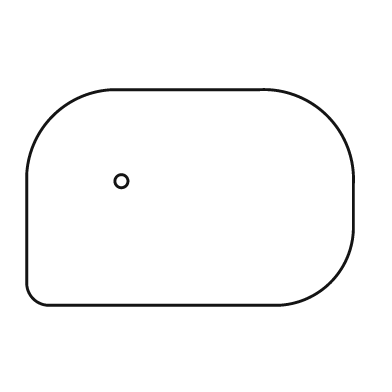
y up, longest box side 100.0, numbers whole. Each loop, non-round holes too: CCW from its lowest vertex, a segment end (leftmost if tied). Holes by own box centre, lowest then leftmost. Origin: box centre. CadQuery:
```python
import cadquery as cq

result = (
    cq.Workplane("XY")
    .moveTo(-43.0, -33.0)
    .lineTo(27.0, -33.0)
    .threePointArc((43.0, -26.0), (50.0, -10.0))
    .lineTo(50.0, 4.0)
    .threePointArc((42.0, 25.0), (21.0, 33.0))
    .lineTo(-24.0, 33.0)
    .threePointArc((-42.0, 25.0), (-50.0, 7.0))
    .lineTo(-50.0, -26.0)
    .threePointArc((-48.0, -31.0), (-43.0, -33.0))
    .close()
    .moveTo(-21.0, 5.0)
    .circle(2.0)
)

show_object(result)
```